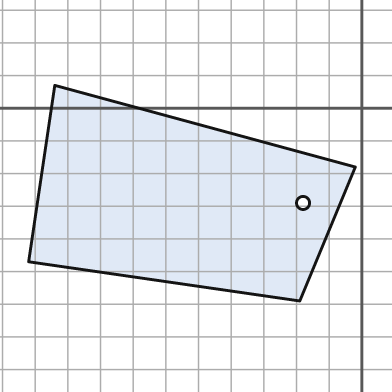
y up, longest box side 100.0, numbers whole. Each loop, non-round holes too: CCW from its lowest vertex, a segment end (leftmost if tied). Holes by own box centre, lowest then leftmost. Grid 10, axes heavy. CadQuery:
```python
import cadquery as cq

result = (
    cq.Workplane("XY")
    .moveTo(-19.0, -59.0)
    .lineTo(-2.0, -18.0)
    .lineTo(-94.0, 7.0)
    .lineTo(-102.0, -47.0)
    .close()
    .moveTo(-18.0, -29.0)
    .circle(2.0)
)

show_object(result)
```